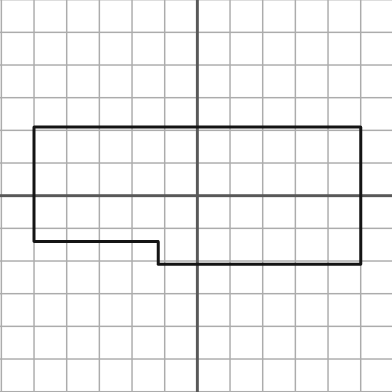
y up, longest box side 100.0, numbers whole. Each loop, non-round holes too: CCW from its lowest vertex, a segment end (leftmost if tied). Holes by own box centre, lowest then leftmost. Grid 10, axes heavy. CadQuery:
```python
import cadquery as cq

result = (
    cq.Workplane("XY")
    .moveTo(-12.0, -21.0)
    .lineTo(50.0, -21.0)
    .lineTo(50.0, 21.0)
    .lineTo(-50.0, 21.0)
    .lineTo(-50.0, -14.0)
    .lineTo(-12.0, -14.0)
    .close()
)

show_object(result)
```